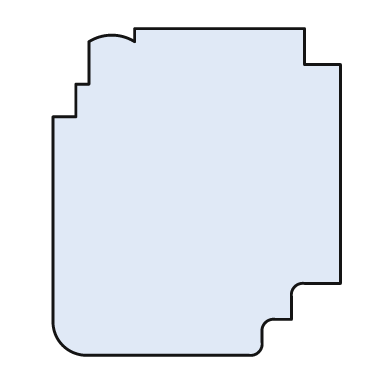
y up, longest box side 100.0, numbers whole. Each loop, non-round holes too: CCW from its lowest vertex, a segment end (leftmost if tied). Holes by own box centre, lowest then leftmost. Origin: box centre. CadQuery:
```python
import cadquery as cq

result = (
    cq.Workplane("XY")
    .moveTo(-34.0, -50.0)
    .lineTo(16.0, -50.0)
    .threePointArc((19.0, -49.0), (20.0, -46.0))
    .lineTo(20.0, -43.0)
    .threePointArc((21.0, -40.0), (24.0, -39.0))
    .lineTo(29.0, -39.0)
    .lineTo(29.0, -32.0)
    .threePointArc((30.0, -29.0), (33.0, -28.0))
    .lineTo(44.0, -28.0)
    .lineTo(44.0, 39.0)
    .lineTo(33.0, 39.0)
    .lineTo(33.0, 50.0)
    .lineTo(-19.0, 50.0)
    .lineTo(-19.0, 46.0)
    .threePointArc((-26.0, 48.0), (-33.0, 46.0))
    .lineTo(-33.0, 33.0)
    .lineTo(-37.0, 33.0)
    .lineTo(-37.0, 23.0)
    .lineTo(-44.0, 23.0)
    .lineTo(-44.0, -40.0)
    .threePointArc((-41.0, -47.0), (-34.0, -50.0))
    .close()
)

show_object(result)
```